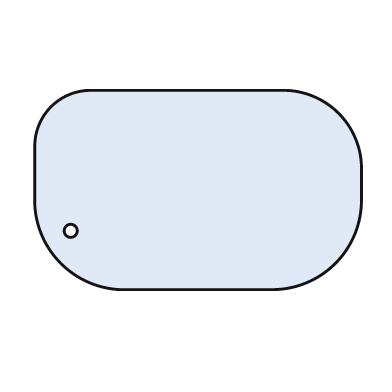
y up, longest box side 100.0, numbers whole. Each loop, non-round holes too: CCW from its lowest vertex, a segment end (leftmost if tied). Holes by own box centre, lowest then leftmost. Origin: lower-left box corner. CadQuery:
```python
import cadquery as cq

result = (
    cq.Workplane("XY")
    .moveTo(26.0, 0.0)
    .lineTo(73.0, 0.0)
    .threePointArc((92.0, 8.0), (100.0, 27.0))
    .lineTo(100.0, 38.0)
    .threePointArc((93.0, 54.0), (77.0, 61.0))
    .lineTo(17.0, 61.0)
    .threePointArc((5.0, 56.0), (0.0, 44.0))
    .lineTo(0.0, 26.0)
    .threePointArc((8.0, 8.0), (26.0, 0.0))
    .close()
    .moveTo(11.0, 18.0)
    .circle(2.0)
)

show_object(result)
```